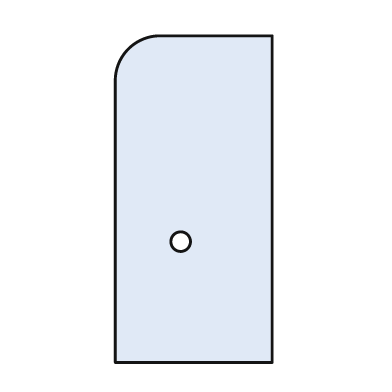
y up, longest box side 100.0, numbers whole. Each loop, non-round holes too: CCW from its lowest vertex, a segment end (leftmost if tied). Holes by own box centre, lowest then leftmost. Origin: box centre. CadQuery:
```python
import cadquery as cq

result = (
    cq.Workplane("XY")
    .moveTo(-24.0, -50.0)
    .lineTo(24.0, -50.0)
    .lineTo(24.0, 50.0)
    .lineTo(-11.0, 50.0)
    .threePointArc((-20.0, 46.0), (-24.0, 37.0))
    .close()
    .moveTo(-4.0, -13.0)
    .circle(3.0)
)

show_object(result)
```